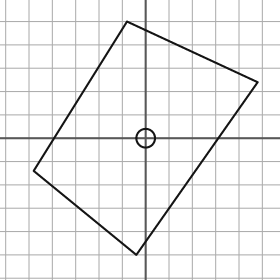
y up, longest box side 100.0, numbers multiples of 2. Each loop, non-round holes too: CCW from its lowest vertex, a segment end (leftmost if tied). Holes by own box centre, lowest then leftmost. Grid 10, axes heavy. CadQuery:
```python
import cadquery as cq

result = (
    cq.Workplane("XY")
    .moveTo(-4.0, -50.0)
    .lineTo(48.0, 24.0)
    .lineTo(-8.0, 50.0)
    .lineTo(-48.0, -14.0)
    .close()
    .moveTo(0.0, 0.0)
    .circle(4.0)
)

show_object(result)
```